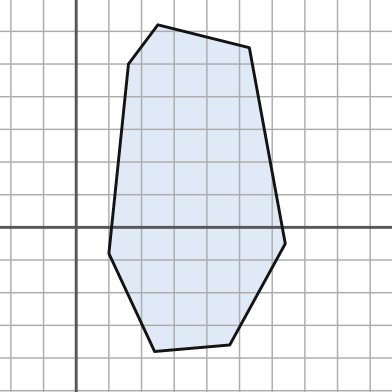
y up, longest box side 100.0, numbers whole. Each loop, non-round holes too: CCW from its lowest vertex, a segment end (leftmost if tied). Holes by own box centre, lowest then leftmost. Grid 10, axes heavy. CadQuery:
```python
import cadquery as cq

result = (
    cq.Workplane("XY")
    .moveTo(24.0, -38.0)
    .lineTo(47.0, -36.0)
    .lineTo(64.0, -5.0)
    .lineTo(53.0, 55.0)
    .lineTo(25.0, 62.0)
    .lineTo(16.0, 50.0)
    .lineTo(10.0, -8.0)
    .close()
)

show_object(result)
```